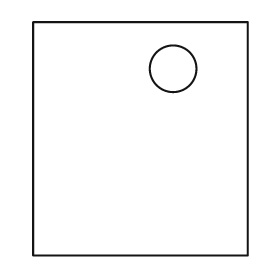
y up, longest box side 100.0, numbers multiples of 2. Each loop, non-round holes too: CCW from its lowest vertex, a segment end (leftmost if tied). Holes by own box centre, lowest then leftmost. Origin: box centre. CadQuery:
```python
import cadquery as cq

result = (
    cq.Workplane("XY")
    .moveTo(-46.0, -50.0)
    .lineTo(46.0, -50.0)
    .lineTo(46.0, 50.0)
    .lineTo(-46.0, 50.0)
    .close()
    .moveTo(14.0, 30.0)
    .circle(10.0)
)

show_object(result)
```